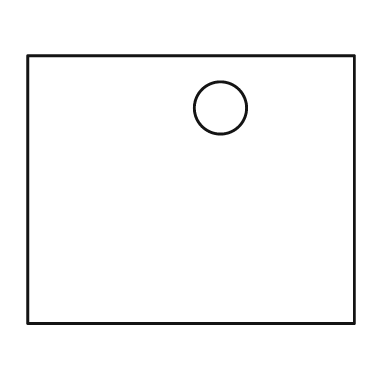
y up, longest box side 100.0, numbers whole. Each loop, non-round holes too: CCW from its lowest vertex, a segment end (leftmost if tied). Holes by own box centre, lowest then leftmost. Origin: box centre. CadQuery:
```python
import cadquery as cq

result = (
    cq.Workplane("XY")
    .moveTo(-50.0, -41.0)
    .lineTo(50.0, -41.0)
    .lineTo(50.0, 41.0)
    .lineTo(-50.0, 41.0)
    .close()
    .moveTo(9.0, 25.0)
    .circle(8.0)
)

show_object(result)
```